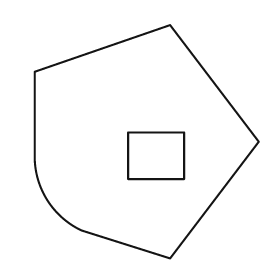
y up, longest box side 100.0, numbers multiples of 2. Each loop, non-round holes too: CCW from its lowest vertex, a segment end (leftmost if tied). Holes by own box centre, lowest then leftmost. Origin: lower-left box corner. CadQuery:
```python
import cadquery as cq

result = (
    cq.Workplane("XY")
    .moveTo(58.0, 0.0)
    .lineTo(96.0, 50.0)
    .lineTo(58.0, 100.0)
    .lineTo(0.0, 80.0)
    .lineTo(0.0, 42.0)
    .threePointArc((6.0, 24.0), (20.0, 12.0))
    .close()
    .moveTo(40.0, 34.0)
    .lineTo(64.0, 34.0)
    .lineTo(64.0, 54.0)
    .lineTo(40.0, 54.0)
    .close()
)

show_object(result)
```